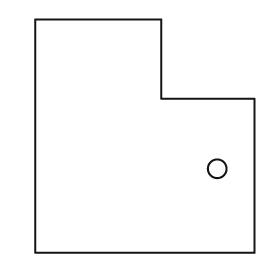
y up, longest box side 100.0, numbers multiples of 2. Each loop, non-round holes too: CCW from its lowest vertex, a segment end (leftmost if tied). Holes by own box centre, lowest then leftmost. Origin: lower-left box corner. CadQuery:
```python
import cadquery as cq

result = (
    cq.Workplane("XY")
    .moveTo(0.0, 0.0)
    .lineTo(94.0, 0.0)
    .lineTo(94.0, 66.0)
    .lineTo(54.0, 66.0)
    .lineTo(54.0, 100.0)
    .lineTo(0.0, 100.0)
    .close()
    .moveTo(78.0, 36.0)
    .circle(4.0)
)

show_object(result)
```